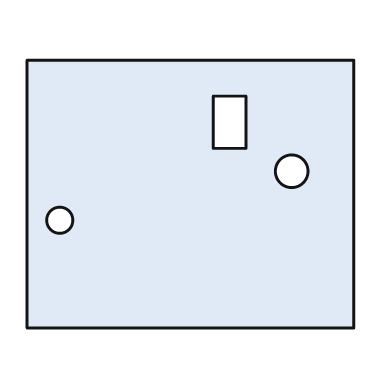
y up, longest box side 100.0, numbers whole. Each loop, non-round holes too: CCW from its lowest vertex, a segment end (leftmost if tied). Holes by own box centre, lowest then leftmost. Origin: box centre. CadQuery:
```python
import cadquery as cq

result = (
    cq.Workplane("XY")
    .moveTo(-50.0, -41.0)
    .lineTo(50.0, -41.0)
    .lineTo(50.0, 41.0)
    .lineTo(-50.0, 41.0)
    .close()
    .moveTo(-40.0, -8.0)
    .circle(4.0)
    .moveTo(31.0, 7.0)
    .circle(5.0)
    .moveTo(7.0, 14.0)
    .lineTo(17.0, 14.0)
    .lineTo(17.0, 30.0)
    .lineTo(7.0, 30.0)
    .close()
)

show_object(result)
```